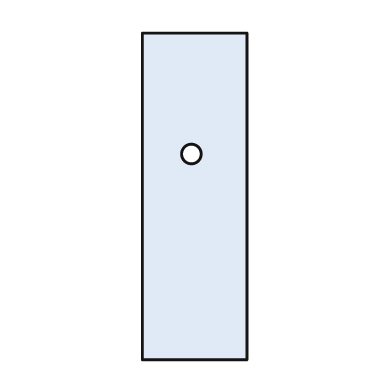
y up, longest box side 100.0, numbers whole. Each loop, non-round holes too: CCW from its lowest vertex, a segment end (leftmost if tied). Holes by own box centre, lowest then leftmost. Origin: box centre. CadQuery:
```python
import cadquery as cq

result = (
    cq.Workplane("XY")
    .moveTo(-16.0, -50.0)
    .lineTo(16.0, -50.0)
    .lineTo(16.0, 50.0)
    .lineTo(-16.0, 50.0)
    .close()
    .moveTo(-1.0, 13.0)
    .circle(3.0)
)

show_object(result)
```